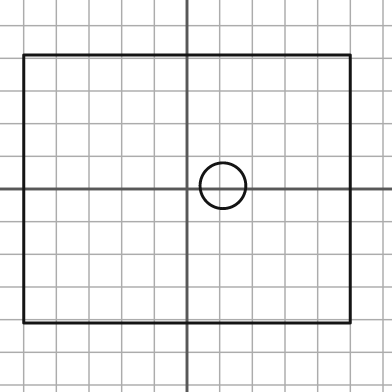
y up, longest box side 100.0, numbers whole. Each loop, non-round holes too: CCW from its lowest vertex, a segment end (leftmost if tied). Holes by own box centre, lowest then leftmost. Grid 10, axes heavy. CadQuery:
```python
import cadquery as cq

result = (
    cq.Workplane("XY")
    .moveTo(-50.0, -41.0)
    .lineTo(50.0, -41.0)
    .lineTo(50.0, 41.0)
    .lineTo(-50.0, 41.0)
    .close()
    .moveTo(11.0, 1.0)
    .circle(7.0)
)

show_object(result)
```